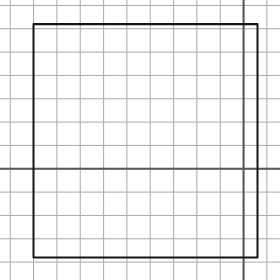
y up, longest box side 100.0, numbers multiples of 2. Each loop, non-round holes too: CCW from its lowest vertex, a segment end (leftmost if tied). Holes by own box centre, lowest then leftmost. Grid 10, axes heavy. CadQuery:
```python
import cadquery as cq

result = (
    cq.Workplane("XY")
    .moveTo(-90.0, -38.0)
    .lineTo(6.0, -38.0)
    .lineTo(6.0, 62.0)
    .lineTo(-90.0, 62.0)
    .close()
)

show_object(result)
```